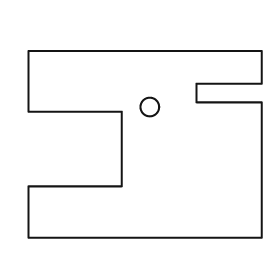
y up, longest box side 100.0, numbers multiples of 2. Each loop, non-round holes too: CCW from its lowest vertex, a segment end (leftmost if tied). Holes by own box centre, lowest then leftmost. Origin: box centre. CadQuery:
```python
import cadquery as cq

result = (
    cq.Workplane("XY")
    .moveTo(-50.0, -40.0)
    .lineTo(50.0, -40.0)
    .lineTo(50.0, 18.0)
    .lineTo(22.0, 18.0)
    .lineTo(22.0, 26.0)
    .lineTo(50.0, 26.0)
    .lineTo(50.0, 40.0)
    .lineTo(-50.0, 40.0)
    .lineTo(-50.0, 14.0)
    .lineTo(-10.0, 14.0)
    .lineTo(-10.0, -18.0)
    .lineTo(-50.0, -18.0)
    .close()
    .moveTo(2.0, 16.0)
    .circle(4.0)
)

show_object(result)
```